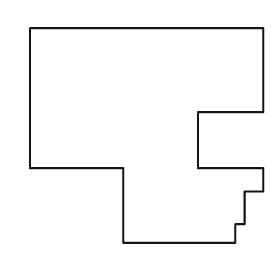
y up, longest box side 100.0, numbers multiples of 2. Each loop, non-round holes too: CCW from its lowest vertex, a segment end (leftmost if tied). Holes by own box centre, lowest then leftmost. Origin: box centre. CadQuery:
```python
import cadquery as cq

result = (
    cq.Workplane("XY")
    .moveTo(-10.0, -46.0)
    .lineTo(38.0, -46.0)
    .lineTo(38.0, -38.0)
    .lineTo(42.0, -38.0)
    .lineTo(42.0, -24.0)
    .lineTo(50.0, -24.0)
    .lineTo(50.0, -14.0)
    .lineTo(22.0, -14.0)
    .lineTo(22.0, 10.0)
    .lineTo(50.0, 10.0)
    .lineTo(50.0, 46.0)
    .lineTo(-50.0, 46.0)
    .lineTo(-50.0, -14.0)
    .lineTo(-10.0, -14.0)
    .close()
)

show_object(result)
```